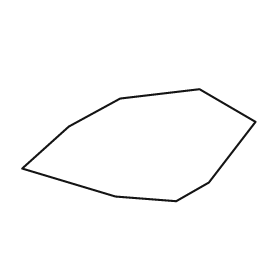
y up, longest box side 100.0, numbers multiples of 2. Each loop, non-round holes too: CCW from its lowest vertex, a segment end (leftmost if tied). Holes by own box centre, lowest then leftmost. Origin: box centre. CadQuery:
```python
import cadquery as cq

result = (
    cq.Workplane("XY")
    .moveTo(16.0, -24.0)
    .lineTo(30.0, -16.0)
    .lineTo(50.0, 10.0)
    .lineTo(26.0, 24.0)
    .lineTo(-8.0, 20.0)
    .lineTo(-30.0, 8.0)
    .lineTo(-50.0, -10.0)
    .lineTo(-10.0, -22.0)
    .close()
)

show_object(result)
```